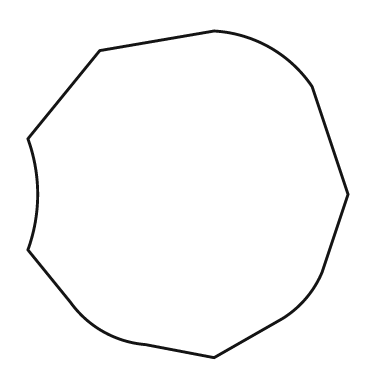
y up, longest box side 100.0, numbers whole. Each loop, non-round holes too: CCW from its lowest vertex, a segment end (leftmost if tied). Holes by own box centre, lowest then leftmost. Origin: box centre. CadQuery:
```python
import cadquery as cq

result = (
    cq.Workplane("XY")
    .moveTo(8.0, -50.0)
    .lineTo(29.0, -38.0)
    .threePointArc((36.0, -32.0), (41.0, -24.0))
    .lineTo(49.0, 0.0)
    .lineTo(38.0, 33.0)
    .threePointArc((25.0, 45.0), (8.0, 50.0))
    .lineTo(-27.0, 44.0)
    .lineTo(-49.0, 17.0)
    .threePointArc((-46.0, 0.0), (-49.0, -17.0))
    .lineTo(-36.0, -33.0)
    .threePointArc((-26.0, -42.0), (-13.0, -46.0))
    .close()
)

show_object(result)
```